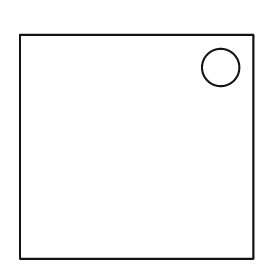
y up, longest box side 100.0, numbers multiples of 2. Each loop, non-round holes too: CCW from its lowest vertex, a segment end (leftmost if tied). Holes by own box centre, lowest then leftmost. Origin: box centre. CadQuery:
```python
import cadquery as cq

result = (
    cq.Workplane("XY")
    .moveTo(-50.0, -48.0)
    .lineTo(50.0, -48.0)
    .lineTo(50.0, 48.0)
    .lineTo(-50.0, 48.0)
    .close()
    .moveTo(36.0, 34.0)
    .circle(8.0)
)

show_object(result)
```